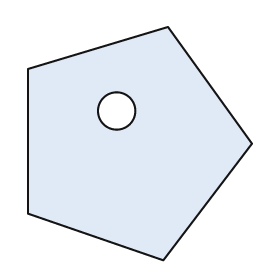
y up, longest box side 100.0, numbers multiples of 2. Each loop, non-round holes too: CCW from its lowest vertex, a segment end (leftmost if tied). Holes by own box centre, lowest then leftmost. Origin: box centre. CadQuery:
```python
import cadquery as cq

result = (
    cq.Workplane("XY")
    .moveTo(10.0, -50.0)
    .lineTo(48.0, 0.0)
    .lineTo(12.0, 50.0)
    .lineTo(-48.0, 32.0)
    .lineTo(-48.0, -30.0)
    .close()
    .moveTo(-10.0, 14.0)
    .circle(8.0)
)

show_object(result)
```